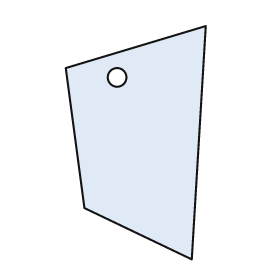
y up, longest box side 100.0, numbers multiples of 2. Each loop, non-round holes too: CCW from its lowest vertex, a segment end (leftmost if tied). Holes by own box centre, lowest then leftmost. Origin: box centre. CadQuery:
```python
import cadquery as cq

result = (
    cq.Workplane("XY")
    .moveTo(24.0, -50.0)
    .lineTo(30.0, 50.0)
    .lineTo(-30.0, 32.0)
    .lineTo(-22.0, -28.0)
    .close()
    .moveTo(-8.0, 28.0)
    .circle(4.0)
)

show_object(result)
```